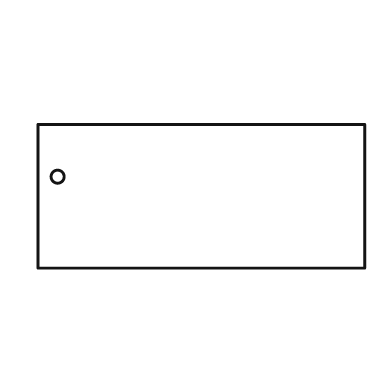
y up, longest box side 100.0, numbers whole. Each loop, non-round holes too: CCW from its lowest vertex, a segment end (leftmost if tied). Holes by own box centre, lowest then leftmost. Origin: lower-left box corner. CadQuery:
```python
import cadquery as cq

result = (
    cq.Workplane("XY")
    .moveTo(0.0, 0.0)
    .lineTo(100.0, 0.0)
    .lineTo(100.0, 44.0)
    .lineTo(0.0, 44.0)
    .close()
    .moveTo(6.0, 28.0)
    .circle(2.0)
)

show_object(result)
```